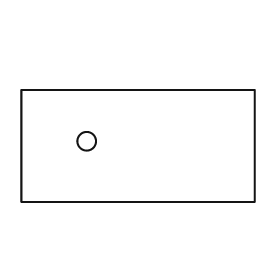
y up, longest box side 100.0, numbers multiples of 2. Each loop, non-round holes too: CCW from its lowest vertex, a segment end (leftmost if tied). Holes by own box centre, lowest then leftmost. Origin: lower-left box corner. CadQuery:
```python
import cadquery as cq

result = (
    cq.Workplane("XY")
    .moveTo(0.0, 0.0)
    .lineTo(100.0, 0.0)
    .lineTo(100.0, 48.0)
    .lineTo(0.0, 48.0)
    .close()
    .moveTo(28.0, 26.0)
    .circle(4.0)
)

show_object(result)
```